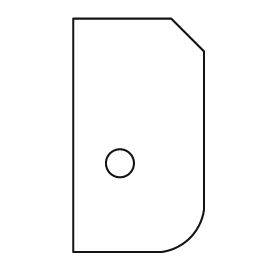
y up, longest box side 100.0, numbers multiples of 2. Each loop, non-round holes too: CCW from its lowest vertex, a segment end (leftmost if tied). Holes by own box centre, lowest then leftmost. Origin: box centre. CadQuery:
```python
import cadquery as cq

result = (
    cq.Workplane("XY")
    .moveTo(-28.0, -50.0)
    .lineTo(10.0, -50.0)
    .threePointArc((22.0, -44.0), (28.0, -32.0))
    .lineTo(28.0, 36.0)
    .lineTo(14.0, 50.0)
    .lineTo(-28.0, 50.0)
    .close()
    .moveTo(-8.0, -12.0)
    .circle(6.0)
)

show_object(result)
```